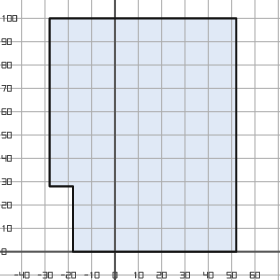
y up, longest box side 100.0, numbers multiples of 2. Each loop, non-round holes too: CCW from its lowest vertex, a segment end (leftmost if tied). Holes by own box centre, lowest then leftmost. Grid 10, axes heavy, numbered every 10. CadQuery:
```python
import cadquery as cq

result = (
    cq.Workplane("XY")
    .moveTo(-18.0, 0.0)
    .lineTo(52.0, 0.0)
    .lineTo(52.0, 100.0)
    .lineTo(-28.0, 100.0)
    .lineTo(-28.0, 28.0)
    .lineTo(-18.0, 28.0)
    .close()
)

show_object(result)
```